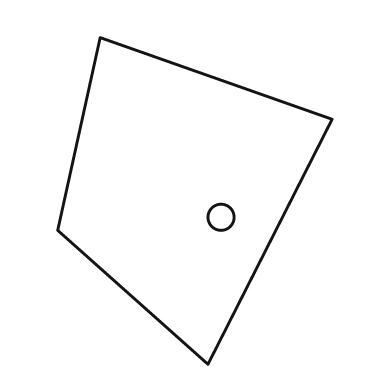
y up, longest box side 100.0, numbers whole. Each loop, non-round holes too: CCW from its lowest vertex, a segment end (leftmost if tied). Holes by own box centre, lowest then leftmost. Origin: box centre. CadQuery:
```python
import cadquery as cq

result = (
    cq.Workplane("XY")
    .moveTo(4.0, -50.0)
    .lineTo(42.0, 25.0)
    .lineTo(-29.0, 50.0)
    .lineTo(-42.0, -9.0)
    .close()
    .moveTo(8.0, -5.0)
    .circle(4.0)
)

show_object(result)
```